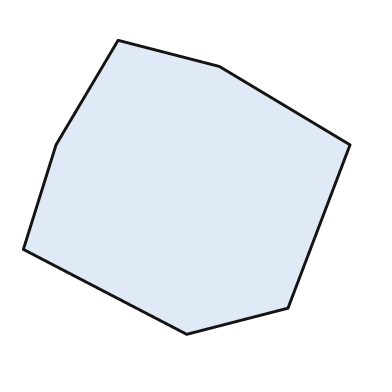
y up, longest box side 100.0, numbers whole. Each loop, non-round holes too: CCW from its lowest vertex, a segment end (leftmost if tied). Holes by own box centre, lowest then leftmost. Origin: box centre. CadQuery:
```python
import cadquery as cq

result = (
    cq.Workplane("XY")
    .moveTo(0.0, -45.0)
    .lineTo(31.0, -37.0)
    .lineTo(50.0, 13.0)
    .lineTo(10.0, 37.0)
    .lineTo(-21.0, 45.0)
    .lineTo(-40.0, 13.0)
    .lineTo(-50.0, -19.0)
    .close()
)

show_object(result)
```